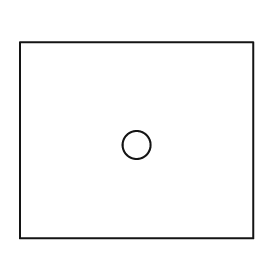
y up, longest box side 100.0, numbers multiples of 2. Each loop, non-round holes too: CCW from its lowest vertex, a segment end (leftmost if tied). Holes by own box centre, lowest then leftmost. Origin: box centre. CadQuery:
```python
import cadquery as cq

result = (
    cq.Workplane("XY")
    .moveTo(-50.0, -42.0)
    .lineTo(50.0, -42.0)
    .lineTo(50.0, 42.0)
    .lineTo(-50.0, 42.0)
    .close()
    .moveTo(0.0, -2.0)
    .circle(6.0)
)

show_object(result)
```